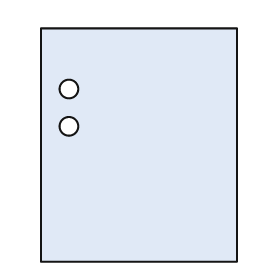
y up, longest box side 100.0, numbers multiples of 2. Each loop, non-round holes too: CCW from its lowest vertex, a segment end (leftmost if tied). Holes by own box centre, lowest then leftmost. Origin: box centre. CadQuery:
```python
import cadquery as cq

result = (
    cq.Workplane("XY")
    .moveTo(-42.0, -50.0)
    .lineTo(42.0, -50.0)
    .lineTo(42.0, 50.0)
    .lineTo(-42.0, 50.0)
    .close()
    .moveTo(-30.0, 8.0)
    .circle(4.0)
    .moveTo(-30.0, 24.0)
    .circle(4.0)
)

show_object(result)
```